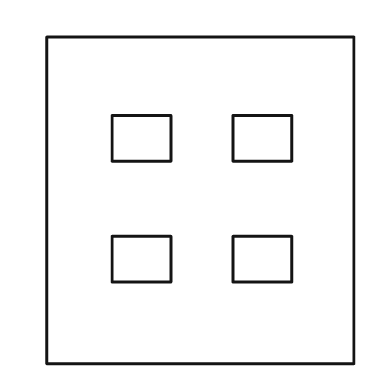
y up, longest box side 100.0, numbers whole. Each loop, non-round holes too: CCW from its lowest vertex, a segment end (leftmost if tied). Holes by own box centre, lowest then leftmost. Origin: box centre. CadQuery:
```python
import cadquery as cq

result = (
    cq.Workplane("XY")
    .moveTo(-47.0, -50.0)
    .lineTo(47.0, -50.0)
    .lineTo(47.0, 50.0)
    .lineTo(-47.0, 50.0)
    .close()
    .moveTo(-27.0, -25.0)
    .lineTo(-9.0, -25.0)
    .lineTo(-9.0, -11.0)
    .lineTo(-27.0, -11.0)
    .close()
    .moveTo(10.0, -25.0)
    .lineTo(28.0, -25.0)
    .lineTo(28.0, -11.0)
    .lineTo(10.0, -11.0)
    .close()
    .moveTo(-27.0, 12.0)
    .lineTo(-9.0, 12.0)
    .lineTo(-9.0, 26.0)
    .lineTo(-27.0, 26.0)
    .close()
    .moveTo(10.0, 12.0)
    .lineTo(28.0, 12.0)
    .lineTo(28.0, 26.0)
    .lineTo(10.0, 26.0)
    .close()
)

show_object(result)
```